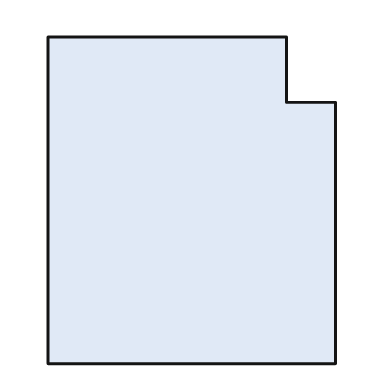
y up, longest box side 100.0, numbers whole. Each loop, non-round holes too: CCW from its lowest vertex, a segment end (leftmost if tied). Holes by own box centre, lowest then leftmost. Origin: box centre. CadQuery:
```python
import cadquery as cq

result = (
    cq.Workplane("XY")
    .moveTo(-44.0, -50.0)
    .lineTo(44.0, -50.0)
    .lineTo(44.0, 30.0)
    .lineTo(29.0, 30.0)
    .lineTo(29.0, 50.0)
    .lineTo(-44.0, 50.0)
    .close()
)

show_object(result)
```